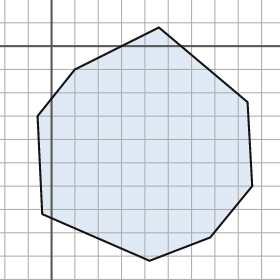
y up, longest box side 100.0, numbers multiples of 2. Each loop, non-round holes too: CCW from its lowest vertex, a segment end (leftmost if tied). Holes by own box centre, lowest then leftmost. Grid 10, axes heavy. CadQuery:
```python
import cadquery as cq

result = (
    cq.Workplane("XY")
    .moveTo(42.0, -92.0)
    .lineTo(68.0, -82.0)
    .lineTo(86.0, -60.0)
    .lineTo(84.0, -24.0)
    .lineTo(46.0, 8.0)
    .lineTo(10.0, -10.0)
    .lineTo(-6.0, -30.0)
    .lineTo(-4.0, -72.0)
    .close()
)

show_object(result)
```